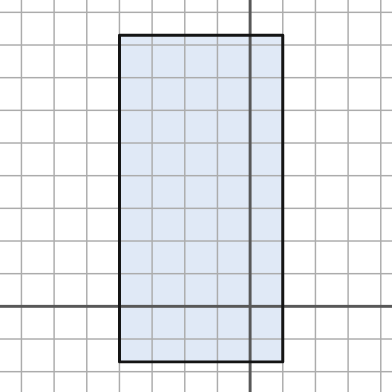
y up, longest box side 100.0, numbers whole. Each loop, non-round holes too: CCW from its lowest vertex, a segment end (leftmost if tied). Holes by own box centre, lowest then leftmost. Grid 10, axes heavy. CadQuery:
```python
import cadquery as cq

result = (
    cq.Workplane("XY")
    .moveTo(-40.0, -17.0)
    .lineTo(10.0, -17.0)
    .lineTo(10.0, 83.0)
    .lineTo(-40.0, 83.0)
    .close()
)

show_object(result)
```